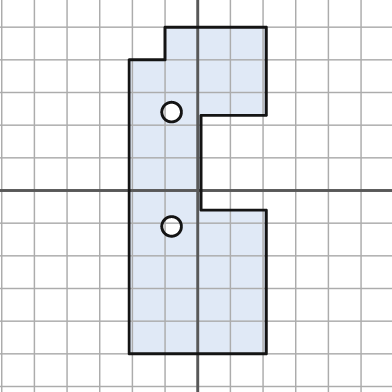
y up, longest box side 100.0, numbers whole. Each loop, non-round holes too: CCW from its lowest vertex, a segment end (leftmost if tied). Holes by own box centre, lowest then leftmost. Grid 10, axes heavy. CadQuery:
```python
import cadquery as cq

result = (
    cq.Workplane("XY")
    .moveTo(-21.0, -50.0)
    .lineTo(21.0, -50.0)
    .lineTo(21.0, -6.0)
    .lineTo(1.0, -6.0)
    .lineTo(1.0, 23.0)
    .lineTo(21.0, 23.0)
    .lineTo(21.0, 50.0)
    .lineTo(-10.0, 50.0)
    .lineTo(-10.0, 40.0)
    .lineTo(-21.0, 40.0)
    .close()
    .moveTo(-8.0, -11.0)
    .circle(3.0)
    .moveTo(-8.0, 24.0)
    .circle(3.0)
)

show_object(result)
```